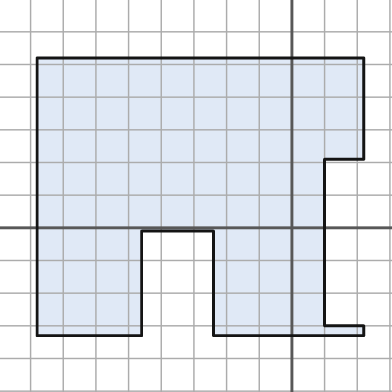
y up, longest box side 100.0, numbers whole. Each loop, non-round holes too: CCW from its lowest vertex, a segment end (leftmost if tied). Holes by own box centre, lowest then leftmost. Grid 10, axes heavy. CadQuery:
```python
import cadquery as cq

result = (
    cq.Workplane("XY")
    .moveTo(-78.0, -33.0)
    .lineTo(-46.0, -33.0)
    .lineTo(-46.0, -1.0)
    .lineTo(-24.0, -1.0)
    .lineTo(-24.0, -33.0)
    .lineTo(22.0, -33.0)
    .lineTo(22.0, -30.0)
    .lineTo(10.0, -30.0)
    .lineTo(10.0, 21.0)
    .lineTo(22.0, 21.0)
    .lineTo(22.0, 52.0)
    .lineTo(-78.0, 52.0)
    .close()
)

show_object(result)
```